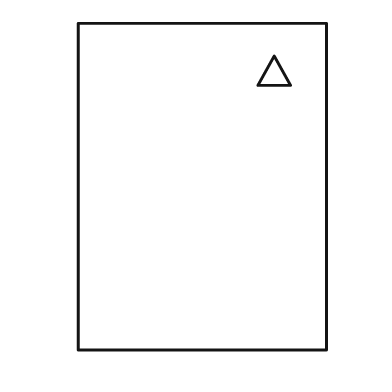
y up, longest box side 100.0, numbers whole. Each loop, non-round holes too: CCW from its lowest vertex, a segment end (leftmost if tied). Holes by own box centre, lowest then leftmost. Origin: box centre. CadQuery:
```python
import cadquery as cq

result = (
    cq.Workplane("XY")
    .moveTo(-38.0, -50.0)
    .lineTo(38.0, -50.0)
    .lineTo(38.0, 50.0)
    .lineTo(-38.0, 50.0)
    .close()
    .moveTo(17.0, 31.0)
    .lineTo(27.0, 31.0)
    .lineTo(22.0, 40.0)
    .close()
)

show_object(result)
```